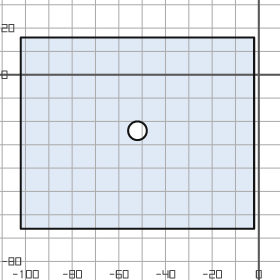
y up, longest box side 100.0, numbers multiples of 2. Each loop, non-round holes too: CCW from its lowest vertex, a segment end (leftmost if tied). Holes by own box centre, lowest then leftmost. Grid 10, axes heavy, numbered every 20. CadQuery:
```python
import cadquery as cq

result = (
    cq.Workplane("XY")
    .moveTo(-102.0, -66.0)
    .lineTo(-2.0, -66.0)
    .lineTo(-2.0, 16.0)
    .lineTo(-102.0, 16.0)
    .close()
    .moveTo(-52.0, -24.0)
    .circle(4.0)
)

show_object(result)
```